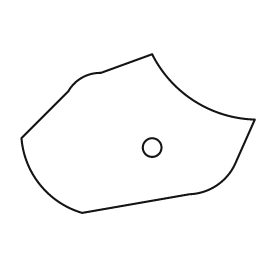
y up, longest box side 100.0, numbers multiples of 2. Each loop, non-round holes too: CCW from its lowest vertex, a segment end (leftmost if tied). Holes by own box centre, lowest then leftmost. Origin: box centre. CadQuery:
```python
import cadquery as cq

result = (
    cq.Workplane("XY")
    .moveTo(-24.0, -34.0)
    .lineTo(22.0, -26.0)
    .threePointArc((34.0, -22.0), (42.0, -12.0))
    .lineTo(50.0, 6.0)
    .threePointArc((24.0, 14.0), (6.0, 34.0))
    .lineTo(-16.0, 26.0)
    .threePointArc((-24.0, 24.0), (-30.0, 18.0))
    .lineTo(-50.0, -2.0)
    .threePointArc((-42.0, -22.0), (-24.0, -34.0))
    .close()
    .moveTo(6.0, -6.0)
    .circle(4.0)
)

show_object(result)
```